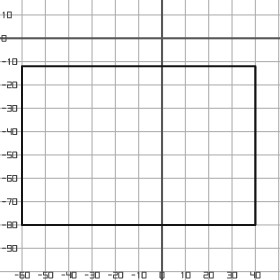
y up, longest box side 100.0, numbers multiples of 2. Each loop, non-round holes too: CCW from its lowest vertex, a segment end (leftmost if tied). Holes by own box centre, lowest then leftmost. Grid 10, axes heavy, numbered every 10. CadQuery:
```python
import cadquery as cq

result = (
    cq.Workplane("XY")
    .moveTo(-60.0, -80.0)
    .lineTo(40.0, -80.0)
    .lineTo(40.0, -12.0)
    .lineTo(-60.0, -12.0)
    .close()
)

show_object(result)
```